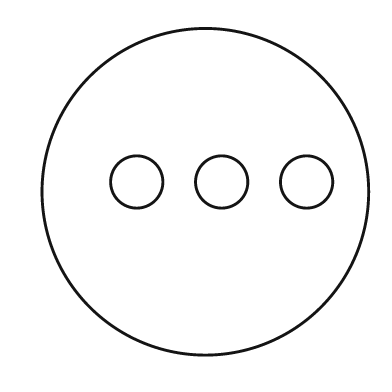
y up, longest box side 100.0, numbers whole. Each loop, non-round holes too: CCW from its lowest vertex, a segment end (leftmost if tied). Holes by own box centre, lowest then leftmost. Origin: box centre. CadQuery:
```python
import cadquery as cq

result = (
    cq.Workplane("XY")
    .moveTo(0.0, 0.0)
    .circle(50.0)
    .moveTo(-21.0, 3.0)
    .circle(8.0)
    .moveTo(5.0, 3.0)
    .circle(8.0)
    .moveTo(31.0, 3.0)
    .circle(8.0)
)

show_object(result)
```